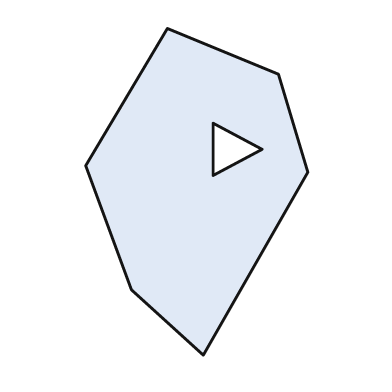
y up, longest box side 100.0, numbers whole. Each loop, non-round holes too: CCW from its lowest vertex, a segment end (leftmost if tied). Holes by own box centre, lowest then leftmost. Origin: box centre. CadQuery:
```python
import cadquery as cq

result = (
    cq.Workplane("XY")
    .moveTo(2.0, -50.0)
    .lineTo(34.0, 6.0)
    .lineTo(25.0, 36.0)
    .lineTo(-9.0, 50.0)
    .lineTo(-34.0, 8.0)
    .lineTo(-20.0, -30.0)
    .close()
    .moveTo(5.0, 5.0)
    .lineTo(20.0, 13.0)
    .lineTo(5.0, 21.0)
    .close()
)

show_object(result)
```